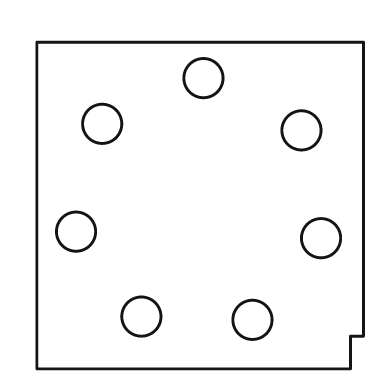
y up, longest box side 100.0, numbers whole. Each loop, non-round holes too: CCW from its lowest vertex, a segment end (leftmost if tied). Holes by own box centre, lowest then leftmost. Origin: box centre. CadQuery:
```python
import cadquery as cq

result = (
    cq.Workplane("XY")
    .moveTo(-50.0, -50.0)
    .lineTo(46.0, -50.0)
    .lineTo(46.0, -40.0)
    .lineTo(50.0, -40.0)
    .lineTo(50.0, 50.0)
    .lineTo(-50.0, 50.0)
    .close()
    .moveTo(16.0, -35.0)
    .circle(6.0)
    .moveTo(-18.0, -34.0)
    .circle(6.0)
    .moveTo(37.0, -10.0)
    .circle(6.0)
    .moveTo(-38.0, -8.0)
    .circle(6.0)
    .moveTo(31.0, 23.0)
    .circle(6.0)
    .moveTo(-30.0, 25.0)
    .circle(6.0)
    .moveTo(1.0, 39.0)
    .circle(6.0)
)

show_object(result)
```